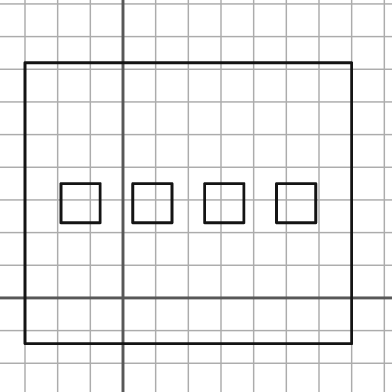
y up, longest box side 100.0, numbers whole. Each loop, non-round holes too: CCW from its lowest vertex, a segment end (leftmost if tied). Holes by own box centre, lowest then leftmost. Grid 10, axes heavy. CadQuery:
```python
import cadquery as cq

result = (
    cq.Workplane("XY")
    .moveTo(-30.0, -14.0)
    .lineTo(70.0, -14.0)
    .lineTo(70.0, 72.0)
    .lineTo(-30.0, 72.0)
    .close()
    .moveTo(-19.0, 23.0)
    .lineTo(-7.0, 23.0)
    .lineTo(-7.0, 35.0)
    .lineTo(-19.0, 35.0)
    .close()
    .moveTo(3.0, 23.0)
    .lineTo(15.0, 23.0)
    .lineTo(15.0, 35.0)
    .lineTo(3.0, 35.0)
    .close()
    .moveTo(25.0, 23.0)
    .lineTo(37.0, 23.0)
    .lineTo(37.0, 35.0)
    .lineTo(25.0, 35.0)
    .close()
    .moveTo(47.0, 23.0)
    .lineTo(59.0, 23.0)
    .lineTo(59.0, 35.0)
    .lineTo(47.0, 35.0)
    .close()
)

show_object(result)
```